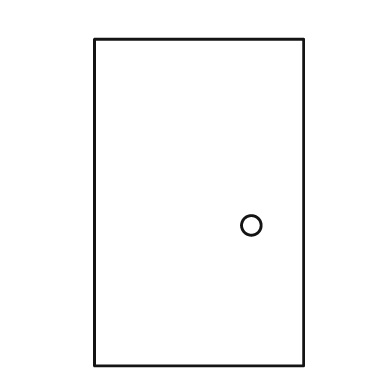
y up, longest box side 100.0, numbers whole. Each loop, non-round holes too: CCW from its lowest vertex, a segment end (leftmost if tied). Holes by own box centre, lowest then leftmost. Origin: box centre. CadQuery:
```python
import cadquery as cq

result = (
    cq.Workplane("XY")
    .moveTo(-32.0, -50.0)
    .lineTo(32.0, -50.0)
    .lineTo(32.0, 50.0)
    .lineTo(-32.0, 50.0)
    .close()
    .moveTo(16.0, -7.0)
    .circle(3.0)
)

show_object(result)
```